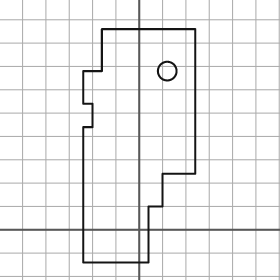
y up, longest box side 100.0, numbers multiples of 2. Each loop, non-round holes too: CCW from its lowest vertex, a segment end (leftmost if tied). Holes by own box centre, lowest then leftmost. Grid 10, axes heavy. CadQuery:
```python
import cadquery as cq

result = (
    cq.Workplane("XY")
    .moveTo(-24.0, -14.0)
    .lineTo(4.0, -14.0)
    .lineTo(4.0, 10.0)
    .lineTo(10.0, 10.0)
    .lineTo(10.0, 24.0)
    .lineTo(24.0, 24.0)
    .lineTo(24.0, 86.0)
    .lineTo(-16.0, 86.0)
    .lineTo(-16.0, 68.0)
    .lineTo(-24.0, 68.0)
    .lineTo(-24.0, 54.0)
    .lineTo(-20.0, 54.0)
    .lineTo(-20.0, 44.0)
    .lineTo(-24.0, 44.0)
    .close()
    .moveTo(12.0, 68.0)
    .circle(4.0)
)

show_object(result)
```